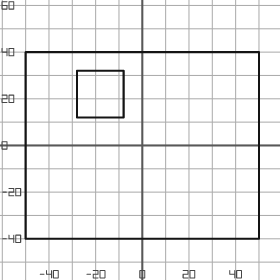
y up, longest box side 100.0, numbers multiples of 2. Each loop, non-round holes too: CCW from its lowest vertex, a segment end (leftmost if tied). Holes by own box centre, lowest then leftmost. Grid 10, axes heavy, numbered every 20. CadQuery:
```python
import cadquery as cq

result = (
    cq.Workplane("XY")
    .moveTo(-50.0, -40.0)
    .lineTo(50.0, -40.0)
    .lineTo(50.0, 40.0)
    .lineTo(-50.0, 40.0)
    .close()
    .moveTo(-28.0, 12.0)
    .lineTo(-8.0, 12.0)
    .lineTo(-8.0, 32.0)
    .lineTo(-28.0, 32.0)
    .close()
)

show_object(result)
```